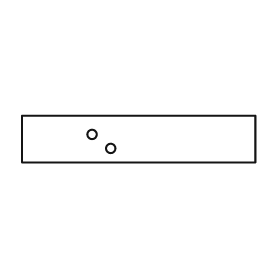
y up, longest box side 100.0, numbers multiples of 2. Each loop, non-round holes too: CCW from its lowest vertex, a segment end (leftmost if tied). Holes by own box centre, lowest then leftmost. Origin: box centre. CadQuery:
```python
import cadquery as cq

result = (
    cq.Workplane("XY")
    .moveTo(-50.0, -10.0)
    .lineTo(50.0, -10.0)
    .lineTo(50.0, 10.0)
    .lineTo(-50.0, 10.0)
    .close()
    .moveTo(-12.0, -4.0)
    .circle(2.0)
    .moveTo(-20.0, 2.0)
    .circle(2.0)
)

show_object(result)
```